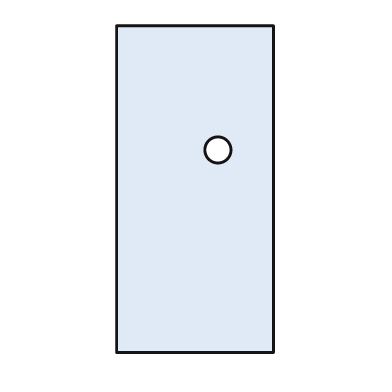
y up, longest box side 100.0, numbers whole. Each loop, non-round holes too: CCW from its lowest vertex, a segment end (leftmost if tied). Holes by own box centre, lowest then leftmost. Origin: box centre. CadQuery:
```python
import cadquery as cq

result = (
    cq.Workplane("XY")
    .moveTo(-24.0, -50.0)
    .lineTo(24.0, -50.0)
    .lineTo(24.0, 50.0)
    .lineTo(-24.0, 50.0)
    .close()
    .moveTo(7.0, 12.0)
    .circle(4.0)
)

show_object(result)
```